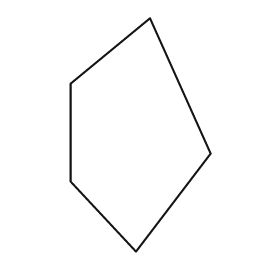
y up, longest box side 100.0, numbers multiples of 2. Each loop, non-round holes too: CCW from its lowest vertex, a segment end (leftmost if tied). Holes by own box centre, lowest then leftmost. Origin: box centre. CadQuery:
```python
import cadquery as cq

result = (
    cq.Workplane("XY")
    .moveTo(-2.0, -50.0)
    .lineTo(30.0, -8.0)
    .lineTo(4.0, 50.0)
    .lineTo(-30.0, 22.0)
    .lineTo(-30.0, -20.0)
    .close()
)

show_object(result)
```